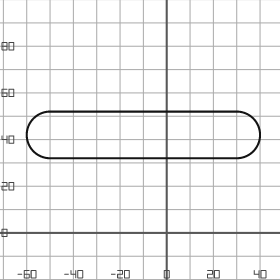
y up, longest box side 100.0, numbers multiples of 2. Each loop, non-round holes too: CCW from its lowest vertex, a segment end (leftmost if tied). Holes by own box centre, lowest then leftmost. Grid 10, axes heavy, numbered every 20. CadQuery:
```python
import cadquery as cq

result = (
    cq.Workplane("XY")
    .moveTo(-50.0, 32.0)
    .lineTo(30.0, 32.0)
    .threePointArc((40.0, 42.0), (30.0, 52.0))
    .lineTo(-50.0, 52.0)
    .threePointArc((-60.0, 42.0), (-50.0, 32.0))
    .close()
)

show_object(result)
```